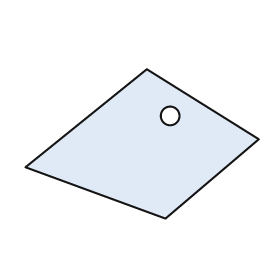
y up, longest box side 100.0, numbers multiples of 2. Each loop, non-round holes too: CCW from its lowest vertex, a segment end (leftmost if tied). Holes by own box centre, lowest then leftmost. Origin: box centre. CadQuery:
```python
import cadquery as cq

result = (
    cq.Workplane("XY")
    .moveTo(10.0, -32.0)
    .lineTo(50.0, 2.0)
    .lineTo(2.0, 32.0)
    .lineTo(-50.0, -10.0)
    .close()
    .moveTo(12.0, 12.0)
    .circle(4.0)
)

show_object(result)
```